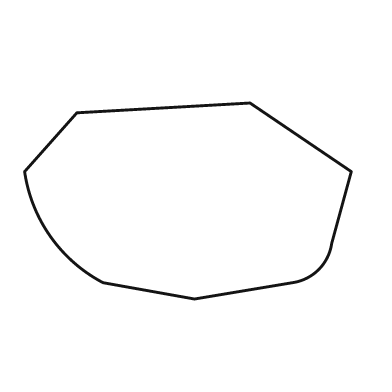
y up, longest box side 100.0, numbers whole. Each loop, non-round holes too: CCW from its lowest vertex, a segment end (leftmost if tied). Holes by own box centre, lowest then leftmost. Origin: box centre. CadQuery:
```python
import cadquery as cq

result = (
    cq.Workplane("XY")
    .moveTo(2.0, -30.0)
    .lineTo(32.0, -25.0)
    .threePointArc((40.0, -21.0), (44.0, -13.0))
    .lineTo(50.0, 9.0)
    .lineTo(19.0, 30.0)
    .lineTo(-34.0, 27.0)
    .lineTo(-50.0, 9.0)
    .threePointArc((-42.0, -11.0), (-26.0, -25.0))
    .close()
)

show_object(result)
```